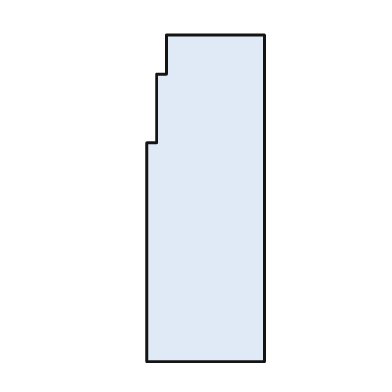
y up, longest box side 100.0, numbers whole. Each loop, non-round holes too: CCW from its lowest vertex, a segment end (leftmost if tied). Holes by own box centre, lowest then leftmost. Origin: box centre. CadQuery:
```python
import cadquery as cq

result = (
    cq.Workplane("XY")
    .moveTo(-18.0, -50.0)
    .lineTo(18.0, -50.0)
    .lineTo(18.0, 50.0)
    .lineTo(-12.0, 50.0)
    .lineTo(-12.0, 38.0)
    .lineTo(-15.0, 38.0)
    .lineTo(-15.0, 17.0)
    .lineTo(-18.0, 17.0)
    .close()
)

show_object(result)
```